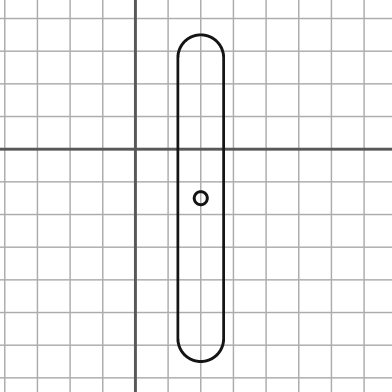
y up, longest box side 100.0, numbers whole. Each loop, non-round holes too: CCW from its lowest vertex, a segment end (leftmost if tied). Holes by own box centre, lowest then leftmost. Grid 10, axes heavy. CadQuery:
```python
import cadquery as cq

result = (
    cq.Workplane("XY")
    .moveTo(13.0, -58.0)
    .threePointArc((20.0, -65.0), (27.0, -58.0))
    .lineTo(27.0, 28.0)
    .threePointArc((20.0, 35.0), (13.0, 28.0))
    .close()
    .moveTo(20.0, -15.0)
    .circle(2.0)
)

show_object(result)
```